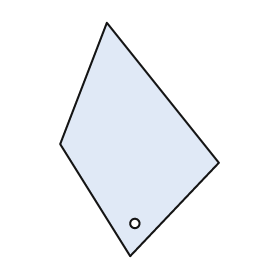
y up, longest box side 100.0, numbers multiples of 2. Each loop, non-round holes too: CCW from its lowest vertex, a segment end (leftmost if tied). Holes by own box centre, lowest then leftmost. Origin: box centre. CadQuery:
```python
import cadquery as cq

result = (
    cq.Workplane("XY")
    .moveTo(-4.0, -50.0)
    .lineTo(34.0, -10.0)
    .lineTo(-14.0, 50.0)
    .lineTo(-34.0, -2.0)
    .close()
    .moveTo(-2.0, -36.0)
    .circle(2.0)
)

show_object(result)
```